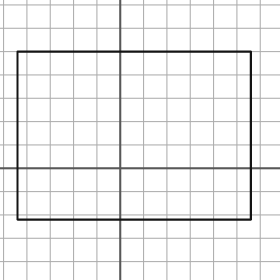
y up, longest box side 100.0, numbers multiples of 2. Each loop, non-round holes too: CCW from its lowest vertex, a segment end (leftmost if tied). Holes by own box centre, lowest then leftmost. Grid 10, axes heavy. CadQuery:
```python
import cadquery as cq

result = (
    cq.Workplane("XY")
    .moveTo(-44.0, -22.0)
    .lineTo(56.0, -22.0)
    .lineTo(56.0, 50.0)
    .lineTo(-44.0, 50.0)
    .close()
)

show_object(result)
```